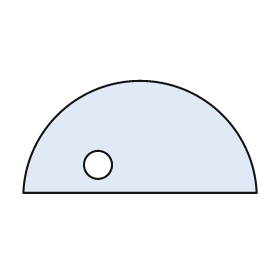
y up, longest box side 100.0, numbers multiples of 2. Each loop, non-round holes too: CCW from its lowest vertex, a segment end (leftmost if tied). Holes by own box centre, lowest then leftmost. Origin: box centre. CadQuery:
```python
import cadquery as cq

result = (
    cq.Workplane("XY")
    .moveTo(-50.0, -24.0)
    .lineTo(50.0, -24.0)
    .threePointArc((0.0, 24.0), (-50.0, -24.0))
    .close()
    .moveTo(-18.0, -12.0)
    .circle(6.0)
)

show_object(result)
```